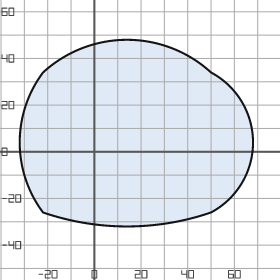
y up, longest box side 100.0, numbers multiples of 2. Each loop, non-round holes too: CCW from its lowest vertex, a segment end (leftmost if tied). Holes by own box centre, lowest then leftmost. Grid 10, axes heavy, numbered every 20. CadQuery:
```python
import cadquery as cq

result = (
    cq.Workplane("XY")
    .moveTo(-22.0, -26.0)
    .threePointArc((14.0, -32.0), (50.0, -26.0))
    .threePointArc((68.0, 4.0), (50.0, 34.0))
    .threePointArc((14.0, 48.0), (-22.0, 34.0))
    .threePointArc((-32.0, 4.0), (-22.0, -26.0))
    .close()
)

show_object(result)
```